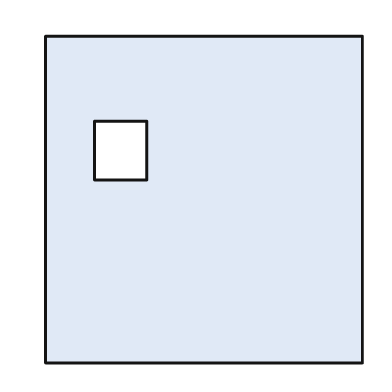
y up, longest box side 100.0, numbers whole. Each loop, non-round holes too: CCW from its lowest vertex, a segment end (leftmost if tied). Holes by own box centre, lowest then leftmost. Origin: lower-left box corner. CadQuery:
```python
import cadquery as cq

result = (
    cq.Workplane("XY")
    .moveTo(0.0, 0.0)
    .lineTo(97.0, 0.0)
    .lineTo(97.0, 100.0)
    .lineTo(0.0, 100.0)
    .close()
    .moveTo(15.0, 56.0)
    .lineTo(31.0, 56.0)
    .lineTo(31.0, 74.0)
    .lineTo(15.0, 74.0)
    .close()
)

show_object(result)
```